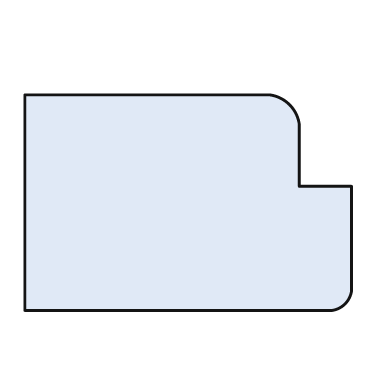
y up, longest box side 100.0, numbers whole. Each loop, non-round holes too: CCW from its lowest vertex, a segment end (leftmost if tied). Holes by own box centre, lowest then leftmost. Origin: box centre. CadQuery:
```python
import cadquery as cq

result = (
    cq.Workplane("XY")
    .moveTo(-50.0, -33.0)
    .lineTo(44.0, -33.0)
    .threePointArc((48.0, -31.0), (50.0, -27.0))
    .lineTo(50.0, 5.0)
    .lineTo(34.0, 5.0)
    .lineTo(34.0, 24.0)
    .threePointArc((31.0, 30.0), (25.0, 33.0))
    .lineTo(-50.0, 33.0)
    .close()
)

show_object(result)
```